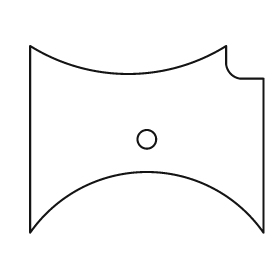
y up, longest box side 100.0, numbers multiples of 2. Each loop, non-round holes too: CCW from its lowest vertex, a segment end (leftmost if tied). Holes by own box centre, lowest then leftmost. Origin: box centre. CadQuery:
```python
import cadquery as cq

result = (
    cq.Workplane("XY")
    .moveTo(-50.0, -40.0)
    .threePointArc((0.0, -14.0), (50.0, -40.0))
    .lineTo(50.0, 26.0)
    .lineTo(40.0, 26.0)
    .threePointArc((36.0, 28.0), (34.0, 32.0))
    .lineTo(34.0, 40.0)
    .threePointArc((-8.0, 28.0), (-50.0, 40.0))
    .close()
    .moveTo(0.0, 0.0)
    .circle(4.0)
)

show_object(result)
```